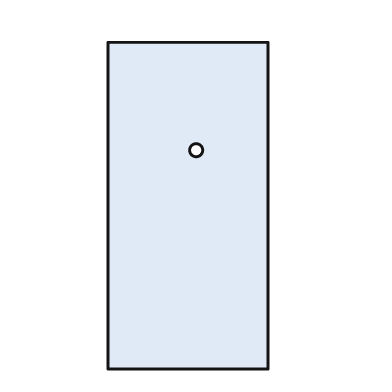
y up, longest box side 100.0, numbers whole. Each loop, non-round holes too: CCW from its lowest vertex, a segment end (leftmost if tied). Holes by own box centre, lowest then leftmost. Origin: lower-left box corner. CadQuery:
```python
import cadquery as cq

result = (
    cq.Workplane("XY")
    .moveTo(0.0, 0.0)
    .lineTo(49.0, 0.0)
    .lineTo(49.0, 100.0)
    .lineTo(0.0, 100.0)
    .close()
    .moveTo(27.0, 67.0)
    .circle(2.0)
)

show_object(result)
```